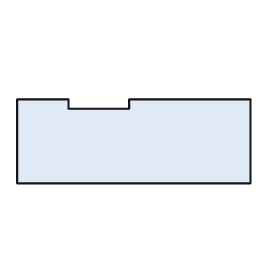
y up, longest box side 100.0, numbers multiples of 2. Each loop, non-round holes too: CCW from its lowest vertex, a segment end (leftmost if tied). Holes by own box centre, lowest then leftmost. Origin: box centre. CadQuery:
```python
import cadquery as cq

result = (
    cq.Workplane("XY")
    .moveTo(-50.0, -18.0)
    .lineTo(50.0, -18.0)
    .lineTo(50.0, 18.0)
    .lineTo(-2.0, 18.0)
    .lineTo(-2.0, 14.0)
    .lineTo(-28.0, 14.0)
    .lineTo(-28.0, 18.0)
    .lineTo(-50.0, 18.0)
    .close()
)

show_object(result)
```